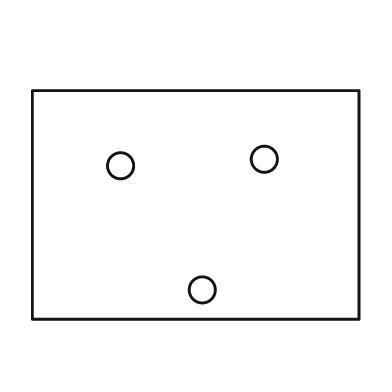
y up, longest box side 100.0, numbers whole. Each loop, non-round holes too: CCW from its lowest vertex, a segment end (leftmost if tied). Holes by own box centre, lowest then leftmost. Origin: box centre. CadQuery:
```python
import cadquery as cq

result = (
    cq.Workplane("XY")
    .moveTo(-50.0, -35.0)
    .lineTo(50.0, -35.0)
    .lineTo(50.0, 35.0)
    .lineTo(-50.0, 35.0)
    .close()
    .moveTo(2.0, -26.0)
    .circle(4.0)
    .moveTo(-23.0, 12.0)
    .circle(4.0)
    .moveTo(21.0, 14.0)
    .circle(4.0)
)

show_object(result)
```